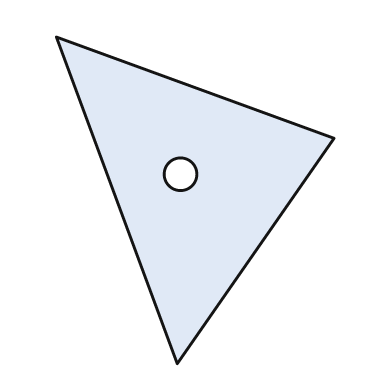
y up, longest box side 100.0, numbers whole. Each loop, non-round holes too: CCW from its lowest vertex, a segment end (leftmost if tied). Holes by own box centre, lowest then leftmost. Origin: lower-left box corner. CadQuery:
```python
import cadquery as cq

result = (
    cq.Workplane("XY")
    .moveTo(37.0, 0.0)
    .lineTo(85.0, 69.0)
    .lineTo(0.0, 100.0)
    .close()
    .moveTo(38.0, 58.0)
    .circle(5.0)
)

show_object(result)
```